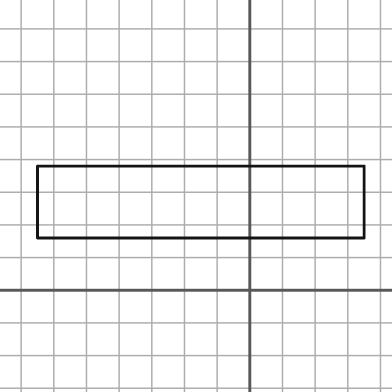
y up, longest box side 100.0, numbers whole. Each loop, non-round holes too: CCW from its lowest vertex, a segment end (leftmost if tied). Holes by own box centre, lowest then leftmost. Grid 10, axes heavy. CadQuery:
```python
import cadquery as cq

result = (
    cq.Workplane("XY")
    .moveTo(-65.0, 16.0)
    .lineTo(35.0, 16.0)
    .lineTo(35.0, 38.0)
    .lineTo(-65.0, 38.0)
    .close()
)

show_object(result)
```